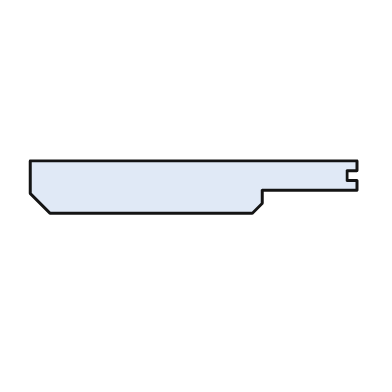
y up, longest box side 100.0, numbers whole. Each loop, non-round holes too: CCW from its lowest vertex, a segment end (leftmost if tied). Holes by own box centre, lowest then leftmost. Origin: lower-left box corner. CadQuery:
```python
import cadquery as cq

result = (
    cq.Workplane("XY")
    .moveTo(6.0, 0.0)
    .lineTo(68.0, 0.0)
    .lineTo(71.0, 3.0)
    .lineTo(71.0, 7.0)
    .lineTo(100.0, 7.0)
    .lineTo(100.0, 10.0)
    .lineTo(97.0, 10.0)
    .lineTo(97.0, 13.0)
    .lineTo(100.0, 13.0)
    .lineTo(100.0, 16.0)
    .lineTo(0.0, 16.0)
    .lineTo(0.0, 6.0)
    .close()
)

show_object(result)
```